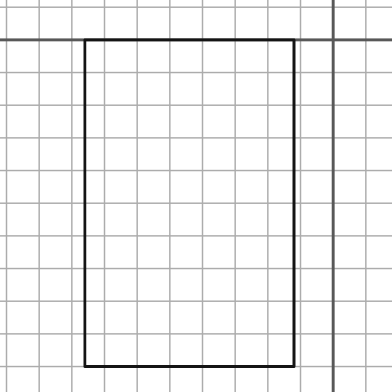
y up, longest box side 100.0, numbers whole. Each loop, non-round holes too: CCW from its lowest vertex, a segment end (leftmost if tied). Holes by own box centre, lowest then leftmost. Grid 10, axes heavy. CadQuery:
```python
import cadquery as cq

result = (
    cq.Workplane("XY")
    .moveTo(-76.0, -100.0)
    .lineTo(-12.0, -100.0)
    .lineTo(-12.0, 0.0)
    .lineTo(-76.0, 0.0)
    .close()
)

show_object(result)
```